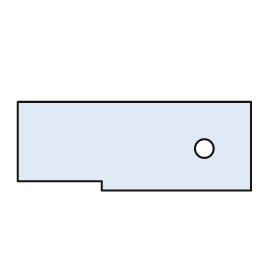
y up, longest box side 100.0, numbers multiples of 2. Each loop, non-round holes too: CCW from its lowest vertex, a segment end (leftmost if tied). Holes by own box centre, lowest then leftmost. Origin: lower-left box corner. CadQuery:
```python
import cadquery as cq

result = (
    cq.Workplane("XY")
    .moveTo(36.0, 0.0)
    .lineTo(100.0, 0.0)
    .lineTo(100.0, 38.0)
    .lineTo(0.0, 38.0)
    .lineTo(0.0, 4.0)
    .lineTo(36.0, 4.0)
    .close()
    .moveTo(80.0, 18.0)
    .circle(4.0)
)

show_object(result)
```